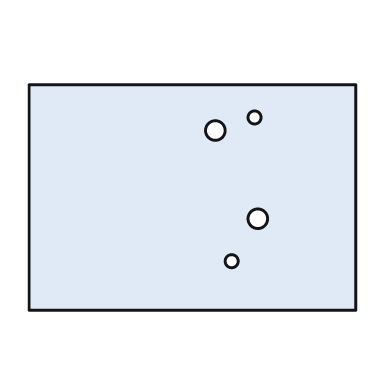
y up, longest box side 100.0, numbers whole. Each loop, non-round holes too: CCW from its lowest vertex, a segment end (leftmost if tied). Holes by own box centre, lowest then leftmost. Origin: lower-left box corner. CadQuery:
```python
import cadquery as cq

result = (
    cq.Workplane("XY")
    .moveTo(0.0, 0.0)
    .lineTo(100.0, 0.0)
    .lineTo(100.0, 69.0)
    .lineTo(0.0, 69.0)
    .close()
    .moveTo(62.0, 15.0)
    .circle(2.0)
    .moveTo(70.0, 28.0)
    .circle(3.0)
    .moveTo(57.0, 55.0)
    .circle(3.0)
    .moveTo(69.0, 59.0)
    .circle(2.0)
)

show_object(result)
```